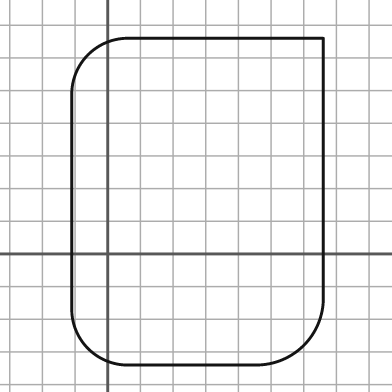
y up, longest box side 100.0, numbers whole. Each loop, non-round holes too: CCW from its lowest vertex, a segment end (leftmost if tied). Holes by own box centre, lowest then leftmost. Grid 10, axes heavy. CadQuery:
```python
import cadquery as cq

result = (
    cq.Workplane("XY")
    .moveTo(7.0, -34.0)
    .lineTo(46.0, -34.0)
    .threePointArc((60.0, -28.0), (66.0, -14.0))
    .lineTo(66.0, 66.0)
    .lineTo(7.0, 66.0)
    .threePointArc((-6.0, 61.0), (-11.0, 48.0))
    .lineTo(-11.0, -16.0)
    .threePointArc((-6.0, -29.0), (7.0, -34.0))
    .close()
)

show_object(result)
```